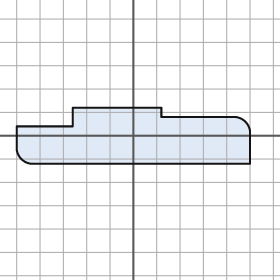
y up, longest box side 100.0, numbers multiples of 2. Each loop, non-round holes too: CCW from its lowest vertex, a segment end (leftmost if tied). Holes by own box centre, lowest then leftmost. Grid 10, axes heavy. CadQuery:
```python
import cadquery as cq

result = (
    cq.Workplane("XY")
    .moveTo(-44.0, -12.0)
    .lineTo(50.0, -12.0)
    .lineTo(50.0, 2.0)
    .threePointArc((48.0, 6.0), (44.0, 8.0))
    .lineTo(12.0, 8.0)
    .lineTo(12.0, 12.0)
    .lineTo(-26.0, 12.0)
    .lineTo(-26.0, 4.0)
    .lineTo(-50.0, 4.0)
    .lineTo(-50.0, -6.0)
    .threePointArc((-48.0, -10.0), (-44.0, -12.0))
    .close()
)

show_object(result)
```